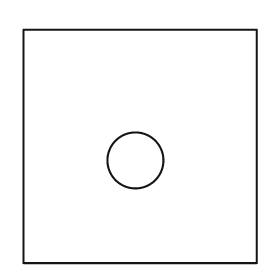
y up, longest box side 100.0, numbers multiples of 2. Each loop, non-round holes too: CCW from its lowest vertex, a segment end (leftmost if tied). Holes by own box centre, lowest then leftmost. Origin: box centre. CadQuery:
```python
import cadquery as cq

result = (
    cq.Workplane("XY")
    .moveTo(-50.0, -50.0)
    .lineTo(50.0, -50.0)
    .lineTo(50.0, 50.0)
    .lineTo(-50.0, 50.0)
    .close()
    .moveTo(-2.0, -6.0)
    .circle(12.0)
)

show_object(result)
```